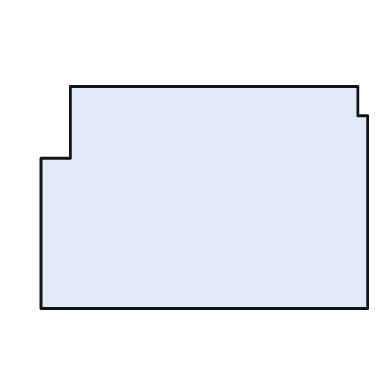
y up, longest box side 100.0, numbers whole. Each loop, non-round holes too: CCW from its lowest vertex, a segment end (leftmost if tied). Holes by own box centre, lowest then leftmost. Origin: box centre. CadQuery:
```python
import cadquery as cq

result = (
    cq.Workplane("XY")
    .moveTo(-50.0, -34.0)
    .lineTo(50.0, -34.0)
    .lineTo(50.0, 25.0)
    .lineTo(47.0, 25.0)
    .lineTo(47.0, 34.0)
    .lineTo(-41.0, 34.0)
    .lineTo(-41.0, 12.0)
    .lineTo(-50.0, 12.0)
    .close()
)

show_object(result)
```